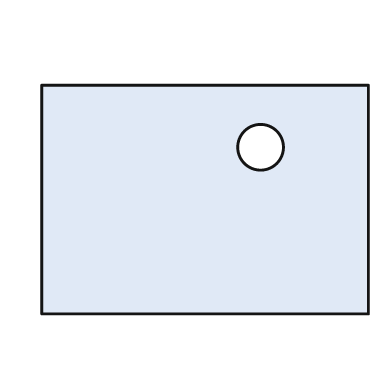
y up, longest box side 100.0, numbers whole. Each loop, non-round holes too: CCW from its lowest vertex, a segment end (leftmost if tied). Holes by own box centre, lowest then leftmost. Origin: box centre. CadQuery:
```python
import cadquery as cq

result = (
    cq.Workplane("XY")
    .moveTo(-50.0, -35.0)
    .lineTo(50.0, -35.0)
    .lineTo(50.0, 35.0)
    .lineTo(-50.0, 35.0)
    .close()
    .moveTo(17.0, 16.0)
    .circle(7.0)
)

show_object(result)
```